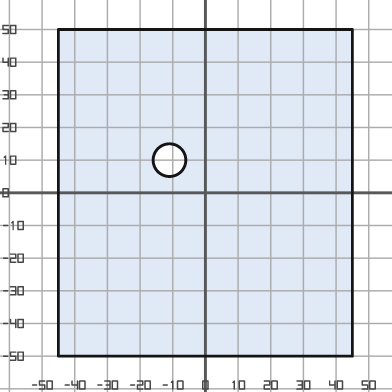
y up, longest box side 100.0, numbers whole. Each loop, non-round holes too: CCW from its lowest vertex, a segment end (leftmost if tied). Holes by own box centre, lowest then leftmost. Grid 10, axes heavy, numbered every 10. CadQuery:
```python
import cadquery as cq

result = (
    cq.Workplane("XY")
    .moveTo(-45.0, -50.0)
    .lineTo(45.0, -50.0)
    .lineTo(45.0, 50.0)
    .lineTo(-45.0, 50.0)
    .close()
    .moveTo(-11.0, 10.0)
    .circle(5.0)
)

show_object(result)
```